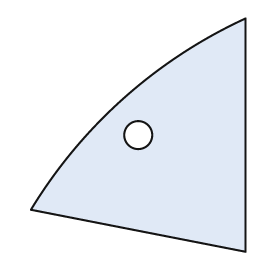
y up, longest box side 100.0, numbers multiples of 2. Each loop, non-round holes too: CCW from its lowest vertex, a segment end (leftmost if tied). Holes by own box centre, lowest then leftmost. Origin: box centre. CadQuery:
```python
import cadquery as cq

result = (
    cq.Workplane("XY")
    .moveTo(46.0, -50.0)
    .lineTo(46.0, 50.0)
    .threePointArc((-6.0, 16.0), (-46.0, -32.0))
    .close()
    .moveTo(0.0, 0.0)
    .circle(6.0)
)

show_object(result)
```